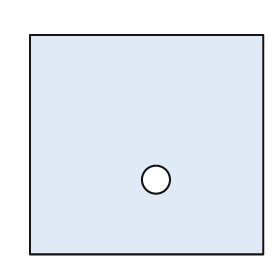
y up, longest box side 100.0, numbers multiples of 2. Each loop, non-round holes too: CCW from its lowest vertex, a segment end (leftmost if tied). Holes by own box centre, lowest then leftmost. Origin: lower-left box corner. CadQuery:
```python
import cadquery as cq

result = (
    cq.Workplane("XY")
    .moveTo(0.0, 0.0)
    .lineTo(100.0, 0.0)
    .lineTo(100.0, 94.0)
    .lineTo(0.0, 94.0)
    .close()
    .moveTo(54.0, 32.0)
    .circle(6.0)
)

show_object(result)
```